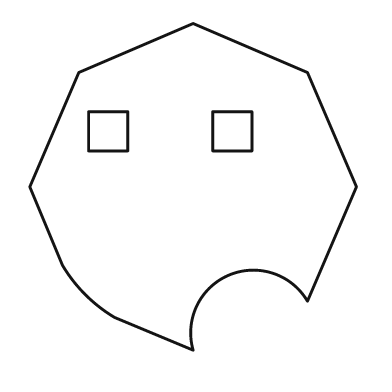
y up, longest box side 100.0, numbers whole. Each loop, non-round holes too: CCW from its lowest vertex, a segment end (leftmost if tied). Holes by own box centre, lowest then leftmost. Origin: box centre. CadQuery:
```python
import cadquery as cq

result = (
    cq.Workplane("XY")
    .moveTo(0.0, -50.0)
    .threePointArc((11.0, -27.0), (35.0, -35.0))
    .lineTo(50.0, 0.0)
    .lineTo(35.0, 35.0)
    .lineTo(0.0, 50.0)
    .lineTo(-35.0, 35.0)
    .lineTo(-50.0, 0.0)
    .lineTo(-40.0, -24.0)
    .threePointArc((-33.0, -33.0), (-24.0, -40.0))
    .close()
    .moveTo(-32.0, 11.0)
    .lineTo(-20.0, 11.0)
    .lineTo(-20.0, 23.0)
    .lineTo(-32.0, 23.0)
    .close()
    .moveTo(6.0, 11.0)
    .lineTo(18.0, 11.0)
    .lineTo(18.0, 23.0)
    .lineTo(6.0, 23.0)
    .close()
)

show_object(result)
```